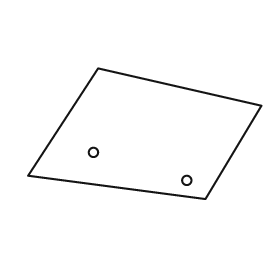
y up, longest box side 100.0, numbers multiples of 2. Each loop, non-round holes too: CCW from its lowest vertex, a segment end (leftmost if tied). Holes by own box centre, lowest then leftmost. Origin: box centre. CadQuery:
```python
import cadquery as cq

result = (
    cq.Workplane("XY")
    .moveTo(26.0, -28.0)
    .lineTo(50.0, 12.0)
    .lineTo(-20.0, 28.0)
    .lineTo(-50.0, -18.0)
    .close()
    .moveTo(18.0, -20.0)
    .circle(2.0)
    .moveTo(-22.0, -8.0)
    .circle(2.0)
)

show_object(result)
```